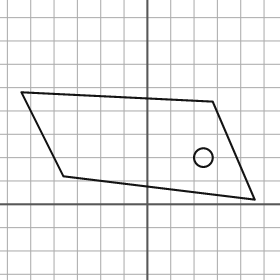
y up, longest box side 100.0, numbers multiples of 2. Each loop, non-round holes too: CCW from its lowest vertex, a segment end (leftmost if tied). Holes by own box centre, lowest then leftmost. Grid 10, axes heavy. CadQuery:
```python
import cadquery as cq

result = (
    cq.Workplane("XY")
    .moveTo(46.0, 2.0)
    .lineTo(28.0, 44.0)
    .lineTo(-54.0, 48.0)
    .lineTo(-36.0, 12.0)
    .close()
    .moveTo(24.0, 20.0)
    .circle(4.0)
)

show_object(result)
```